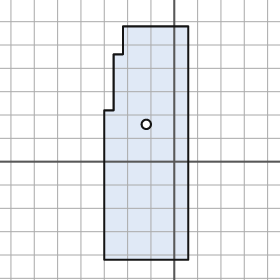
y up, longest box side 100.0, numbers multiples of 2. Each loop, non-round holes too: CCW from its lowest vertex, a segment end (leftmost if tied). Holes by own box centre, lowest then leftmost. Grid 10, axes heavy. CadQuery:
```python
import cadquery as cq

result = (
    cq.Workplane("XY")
    .moveTo(-30.0, -42.0)
    .lineTo(6.0, -42.0)
    .lineTo(6.0, 58.0)
    .lineTo(-22.0, 58.0)
    .lineTo(-22.0, 46.0)
    .lineTo(-26.0, 46.0)
    .lineTo(-26.0, 22.0)
    .lineTo(-30.0, 22.0)
    .close()
    .moveTo(-12.0, 16.0)
    .circle(2.0)
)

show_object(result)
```